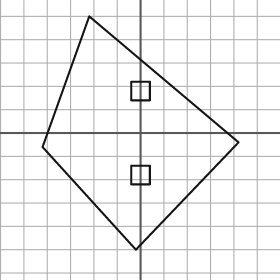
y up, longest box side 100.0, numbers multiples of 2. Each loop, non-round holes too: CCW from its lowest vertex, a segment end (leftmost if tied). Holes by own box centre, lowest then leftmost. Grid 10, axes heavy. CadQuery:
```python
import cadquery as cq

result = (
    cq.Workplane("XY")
    .moveTo(-2.0, -50.0)
    .lineTo(42.0, -4.0)
    .lineTo(-22.0, 50.0)
    .lineTo(-42.0, -6.0)
    .close()
    .moveTo(-4.0, -22.0)
    .lineTo(4.0, -22.0)
    .lineTo(4.0, -14.0)
    .lineTo(-4.0, -14.0)
    .close()
    .moveTo(-4.0, 14.0)
    .lineTo(4.0, 14.0)
    .lineTo(4.0, 22.0)
    .lineTo(-4.0, 22.0)
    .close()
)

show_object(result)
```